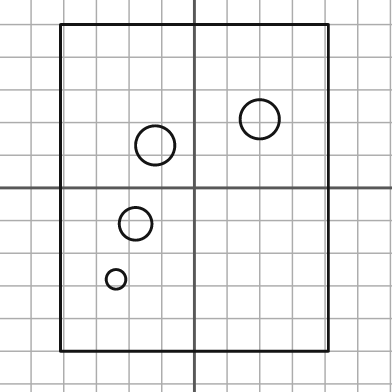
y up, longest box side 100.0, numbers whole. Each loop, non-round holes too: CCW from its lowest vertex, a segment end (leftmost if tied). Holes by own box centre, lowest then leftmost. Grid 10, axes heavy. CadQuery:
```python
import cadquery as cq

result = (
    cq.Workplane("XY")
    .moveTo(-41.0, -50.0)
    .lineTo(41.0, -50.0)
    .lineTo(41.0, 50.0)
    .lineTo(-41.0, 50.0)
    .close()
    .moveTo(-24.0, -28.0)
    .circle(3.0)
    .moveTo(-18.0, -11.0)
    .circle(5.0)
    .moveTo(-12.0, 13.0)
    .circle(6.0)
    .moveTo(20.0, 21.0)
    .circle(6.0)
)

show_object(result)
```